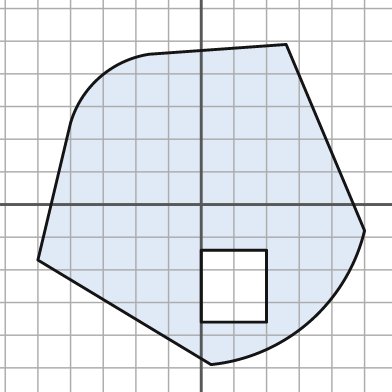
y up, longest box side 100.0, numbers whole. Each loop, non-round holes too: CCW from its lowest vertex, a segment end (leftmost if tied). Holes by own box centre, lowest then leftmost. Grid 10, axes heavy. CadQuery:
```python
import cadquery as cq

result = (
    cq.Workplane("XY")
    .moveTo(3.0, -49.0)
    .threePointArc((33.0, -36.0), (50.0, -8.0))
    .lineTo(26.0, 49.0)
    .lineTo(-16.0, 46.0)
    .threePointArc((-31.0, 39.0), (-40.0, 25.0))
    .lineTo(-50.0, -17.0)
    .close()
    .moveTo(0.0, -36.0)
    .lineTo(20.0, -36.0)
    .lineTo(20.0, -14.0)
    .lineTo(0.0, -14.0)
    .close()
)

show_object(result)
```